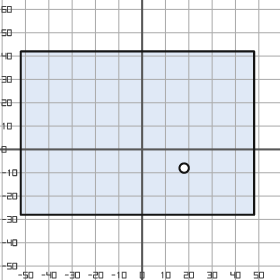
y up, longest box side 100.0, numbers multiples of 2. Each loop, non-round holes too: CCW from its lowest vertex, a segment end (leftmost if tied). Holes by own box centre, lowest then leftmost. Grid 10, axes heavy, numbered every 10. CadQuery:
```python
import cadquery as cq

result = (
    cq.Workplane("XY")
    .moveTo(-52.0, -28.0)
    .lineTo(48.0, -28.0)
    .lineTo(48.0, 42.0)
    .lineTo(-52.0, 42.0)
    .close()
    .moveTo(18.0, -8.0)
    .circle(2.0)
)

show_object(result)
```